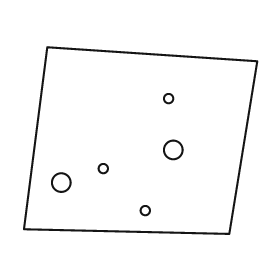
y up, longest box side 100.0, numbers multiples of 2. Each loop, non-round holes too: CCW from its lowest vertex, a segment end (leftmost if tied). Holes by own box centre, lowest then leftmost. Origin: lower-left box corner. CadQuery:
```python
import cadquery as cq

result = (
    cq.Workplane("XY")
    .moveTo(88.0, 0.0)
    .lineTo(100.0, 74.0)
    .lineTo(10.0, 80.0)
    .lineTo(0.0, 2.0)
    .close()
    .moveTo(52.0, 10.0)
    .circle(2.0)
    .moveTo(16.0, 22.0)
    .circle(4.0)
    .moveTo(34.0, 28.0)
    .circle(2.0)
    .moveTo(64.0, 36.0)
    .circle(4.0)
    .moveTo(62.0, 58.0)
    .circle(2.0)
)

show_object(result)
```